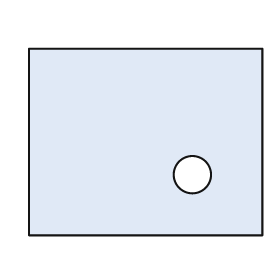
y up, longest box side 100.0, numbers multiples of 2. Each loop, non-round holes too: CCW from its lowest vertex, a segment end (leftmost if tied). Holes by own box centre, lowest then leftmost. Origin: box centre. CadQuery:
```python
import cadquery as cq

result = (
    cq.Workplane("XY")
    .moveTo(-50.0, -40.0)
    .lineTo(50.0, -40.0)
    .lineTo(50.0, 40.0)
    .lineTo(-50.0, 40.0)
    .close()
    .moveTo(20.0, -14.0)
    .circle(8.0)
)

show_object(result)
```